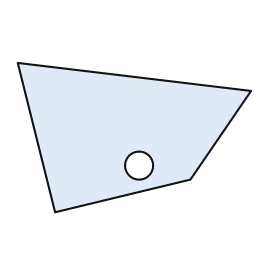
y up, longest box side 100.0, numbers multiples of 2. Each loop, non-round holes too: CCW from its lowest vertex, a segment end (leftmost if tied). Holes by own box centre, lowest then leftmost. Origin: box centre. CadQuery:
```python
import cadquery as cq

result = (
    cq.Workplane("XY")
    .moveTo(-34.0, -32.0)
    .lineTo(24.0, -18.0)
    .lineTo(50.0, 20.0)
    .lineTo(-50.0, 32.0)
    .close()
    .moveTo(2.0, -12.0)
    .circle(6.0)
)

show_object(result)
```